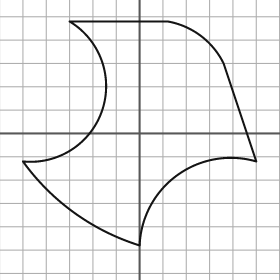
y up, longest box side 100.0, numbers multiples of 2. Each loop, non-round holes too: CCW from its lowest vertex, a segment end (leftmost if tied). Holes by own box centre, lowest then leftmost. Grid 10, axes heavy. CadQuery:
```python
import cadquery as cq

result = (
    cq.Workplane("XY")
    .moveTo(0.0, -48.0)
    .threePointArc((16.0, -18.0), (50.0, -12.0))
    .lineTo(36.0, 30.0)
    .threePointArc((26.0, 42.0), (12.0, 48.0))
    .lineTo(-30.0, 48.0)
    .threePointArc((-16.0, 10.0), (-50.0, -12.0))
    .threePointArc((-28.0, -34.0), (0.0, -48.0))
    .close()
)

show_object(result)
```